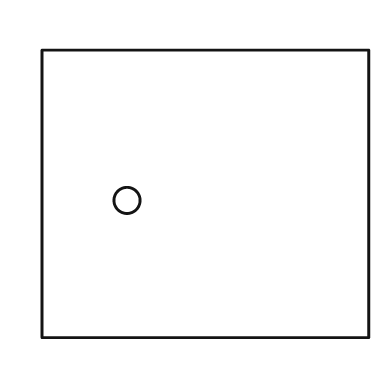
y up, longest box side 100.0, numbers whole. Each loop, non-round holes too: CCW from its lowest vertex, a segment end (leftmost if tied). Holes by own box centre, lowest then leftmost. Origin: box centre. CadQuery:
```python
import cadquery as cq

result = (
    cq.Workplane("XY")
    .moveTo(-50.0, -44.0)
    .lineTo(50.0, -44.0)
    .lineTo(50.0, 44.0)
    .lineTo(-50.0, 44.0)
    .close()
    .moveTo(-24.0, -2.0)
    .circle(4.0)
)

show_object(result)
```